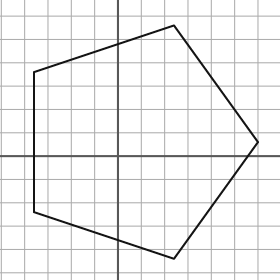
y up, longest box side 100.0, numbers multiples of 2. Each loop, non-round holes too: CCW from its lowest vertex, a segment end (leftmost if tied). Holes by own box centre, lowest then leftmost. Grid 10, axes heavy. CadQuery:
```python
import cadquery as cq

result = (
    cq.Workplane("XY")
    .moveTo(24.0, -44.0)
    .lineTo(60.0, 6.0)
    .lineTo(24.0, 56.0)
    .lineTo(-36.0, 36.0)
    .lineTo(-36.0, -24.0)
    .close()
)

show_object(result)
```